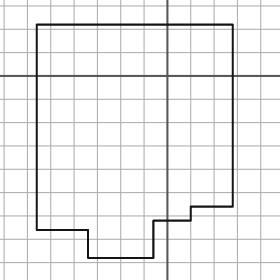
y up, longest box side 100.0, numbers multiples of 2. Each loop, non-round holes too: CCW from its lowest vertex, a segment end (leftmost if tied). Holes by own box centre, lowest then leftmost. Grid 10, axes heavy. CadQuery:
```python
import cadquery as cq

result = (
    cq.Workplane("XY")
    .moveTo(-34.0, -78.0)
    .lineTo(-6.0, -78.0)
    .lineTo(-6.0, -62.0)
    .lineTo(10.0, -62.0)
    .lineTo(10.0, -56.0)
    .lineTo(28.0, -56.0)
    .lineTo(28.0, 22.0)
    .lineTo(-56.0, 22.0)
    .lineTo(-56.0, -66.0)
    .lineTo(-34.0, -66.0)
    .close()
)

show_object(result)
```